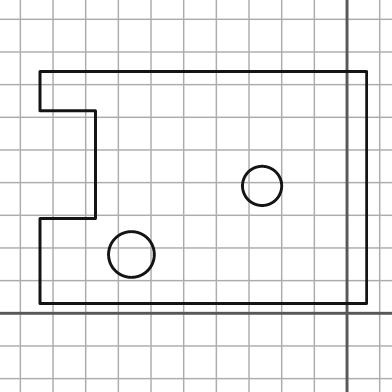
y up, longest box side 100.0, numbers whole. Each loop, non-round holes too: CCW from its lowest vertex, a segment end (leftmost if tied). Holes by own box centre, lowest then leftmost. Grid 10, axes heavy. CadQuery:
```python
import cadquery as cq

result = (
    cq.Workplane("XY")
    .moveTo(-94.0, 3.0)
    .lineTo(6.0, 3.0)
    .lineTo(6.0, 74.0)
    .lineTo(-94.0, 74.0)
    .lineTo(-94.0, 62.0)
    .lineTo(-77.0, 62.0)
    .lineTo(-77.0, 29.0)
    .lineTo(-94.0, 29.0)
    .close()
    .moveTo(-66.0, 18.0)
    .circle(7.0)
    .moveTo(-26.0, 39.0)
    .circle(6.0)
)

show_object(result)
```